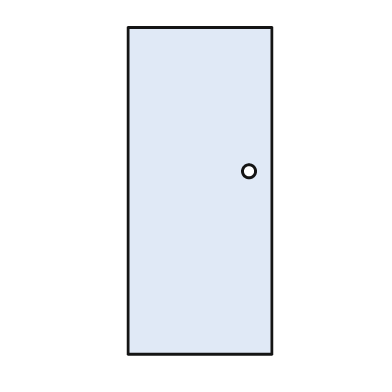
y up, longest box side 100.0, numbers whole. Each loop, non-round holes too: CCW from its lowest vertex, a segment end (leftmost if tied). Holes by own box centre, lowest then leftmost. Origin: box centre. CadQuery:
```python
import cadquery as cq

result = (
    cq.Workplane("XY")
    .moveTo(-22.0, -50.0)
    .lineTo(22.0, -50.0)
    .lineTo(22.0, 50.0)
    .lineTo(-22.0, 50.0)
    .close()
    .moveTo(15.0, 6.0)
    .circle(2.0)
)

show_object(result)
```